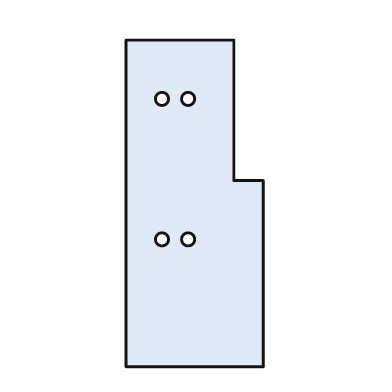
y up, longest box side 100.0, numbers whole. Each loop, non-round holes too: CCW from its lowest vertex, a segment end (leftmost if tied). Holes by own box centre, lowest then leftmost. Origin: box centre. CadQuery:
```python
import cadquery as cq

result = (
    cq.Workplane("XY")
    .moveTo(-21.0, -50.0)
    .lineTo(21.0, -50.0)
    .lineTo(21.0, 7.0)
    .lineTo(12.0, 7.0)
    .lineTo(12.0, 50.0)
    .lineTo(-21.0, 50.0)
    .close()
    .moveTo(-10.0, -11.0)
    .circle(2.0)
    .moveTo(-2.0, -11.0)
    .circle(2.0)
    .moveTo(-10.0, 32.0)
    .circle(2.0)
    .moveTo(-2.0, 32.0)
    .circle(2.0)
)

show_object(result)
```